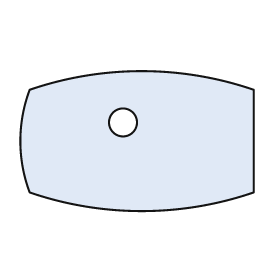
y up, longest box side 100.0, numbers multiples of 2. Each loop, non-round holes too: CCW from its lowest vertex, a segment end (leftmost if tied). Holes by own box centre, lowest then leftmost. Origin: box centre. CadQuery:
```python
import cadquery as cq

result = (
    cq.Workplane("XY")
    .moveTo(-46.0, -22.0)
    .threePointArc((2.0, -30.0), (50.0, -22.0))
    .lineTo(50.0, 22.0)
    .threePointArc((2.0, 30.0), (-46.0, 22.0))
    .threePointArc((-50.0, 0.0), (-46.0, -22.0))
    .close()
    .moveTo(-6.0, 8.0)
    .circle(6.0)
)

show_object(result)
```